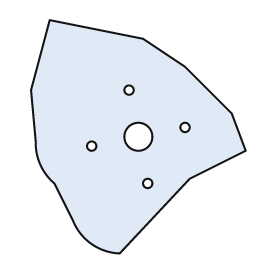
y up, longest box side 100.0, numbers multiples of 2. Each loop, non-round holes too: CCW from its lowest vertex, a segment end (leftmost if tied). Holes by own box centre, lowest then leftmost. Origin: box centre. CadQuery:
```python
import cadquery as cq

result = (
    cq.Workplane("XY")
    .moveTo(-8.0, -50.0)
    .lineTo(22.0, -18.0)
    .lineTo(46.0, -6.0)
    .lineTo(40.0, 10.0)
    .lineTo(20.0, 30.0)
    .lineTo(2.0, 42.0)
    .lineTo(-38.0, 50.0)
    .lineTo(-46.0, 20.0)
    .lineTo(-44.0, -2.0)
    .threePointArc((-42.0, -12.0), (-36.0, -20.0))
    .lineTo(-28.0, -36.0)
    .threePointArc((-20.0, -46.0), (-8.0, -50.0))
    .close()
    .moveTo(4.0, -20.0)
    .circle(2.0)
    .moveTo(-20.0, -4.0)
    .circle(2.0)
    .moveTo(0.0, 0.0)
    .circle(6.0)
    .moveTo(20.0, 4.0)
    .circle(2.0)
    .moveTo(-4.0, 20.0)
    .circle(2.0)
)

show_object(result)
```